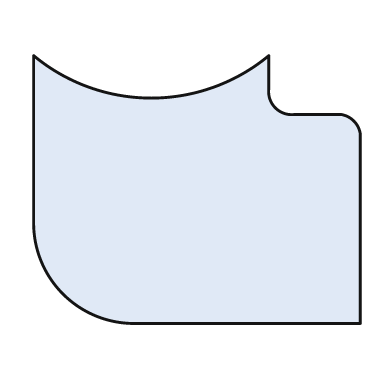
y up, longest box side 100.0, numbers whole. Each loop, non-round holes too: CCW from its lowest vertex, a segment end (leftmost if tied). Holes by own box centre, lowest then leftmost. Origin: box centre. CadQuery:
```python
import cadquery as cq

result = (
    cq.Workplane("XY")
    .moveTo(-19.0, -41.0)
    .lineTo(50.0, -41.0)
    .lineTo(50.0, 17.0)
    .threePointArc((48.0, 21.0), (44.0, 23.0))
    .lineTo(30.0, 23.0)
    .threePointArc((24.0, 25.0), (22.0, 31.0))
    .lineTo(22.0, 41.0)
    .threePointArc((-14.0, 28.0), (-50.0, 41.0))
    .lineTo(-50.0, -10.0)
    .threePointArc((-41.0, -32.0), (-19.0, -41.0))
    .close()
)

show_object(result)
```